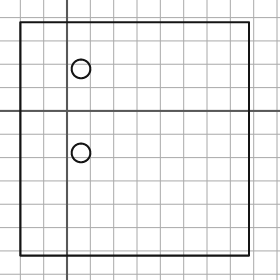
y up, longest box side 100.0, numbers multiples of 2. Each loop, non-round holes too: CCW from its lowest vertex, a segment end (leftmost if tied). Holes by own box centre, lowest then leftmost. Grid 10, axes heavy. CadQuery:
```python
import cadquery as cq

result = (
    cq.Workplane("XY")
    .moveTo(-20.0, -62.0)
    .lineTo(78.0, -62.0)
    .lineTo(78.0, 38.0)
    .lineTo(-20.0, 38.0)
    .close()
    .moveTo(6.0, -18.0)
    .circle(4.0)
    .moveTo(6.0, 18.0)
    .circle(4.0)
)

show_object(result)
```